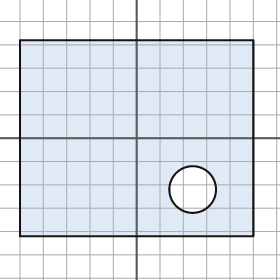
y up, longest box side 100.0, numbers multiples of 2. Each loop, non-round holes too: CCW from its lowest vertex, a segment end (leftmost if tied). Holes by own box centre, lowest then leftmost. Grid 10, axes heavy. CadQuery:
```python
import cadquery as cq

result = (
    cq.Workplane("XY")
    .moveTo(-50.0, -42.0)
    .lineTo(50.0, -42.0)
    .lineTo(50.0, 42.0)
    .lineTo(-50.0, 42.0)
    .close()
    .moveTo(24.0, -22.0)
    .circle(10.0)
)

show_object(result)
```